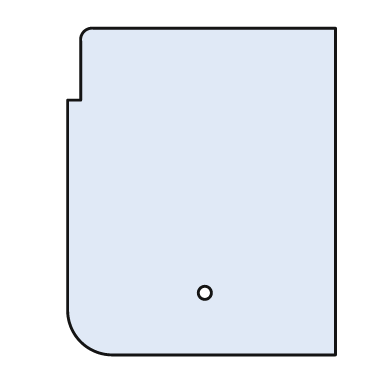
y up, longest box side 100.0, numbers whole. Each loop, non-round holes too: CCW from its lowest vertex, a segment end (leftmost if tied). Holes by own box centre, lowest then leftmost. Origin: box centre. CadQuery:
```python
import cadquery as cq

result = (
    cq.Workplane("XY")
    .moveTo(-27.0, -50.0)
    .lineTo(41.0, -50.0)
    .lineTo(41.0, 50.0)
    .lineTo(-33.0, 50.0)
    .threePointArc((-36.0, 49.0), (-37.0, 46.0))
    .lineTo(-37.0, 28.0)
    .lineTo(-41.0, 28.0)
    .lineTo(-41.0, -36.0)
    .threePointArc((-37.0, -46.0), (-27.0, -50.0))
    .close()
    .moveTo(1.0, -31.0)
    .circle(2.0)
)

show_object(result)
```